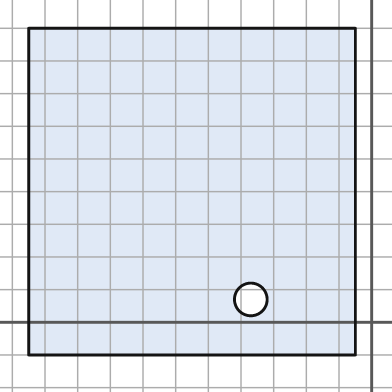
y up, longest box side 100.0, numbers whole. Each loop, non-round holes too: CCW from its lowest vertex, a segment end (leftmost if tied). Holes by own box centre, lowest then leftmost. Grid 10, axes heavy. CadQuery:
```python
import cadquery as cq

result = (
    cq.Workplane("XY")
    .moveTo(-105.0, -10.0)
    .lineTo(-5.0, -10.0)
    .lineTo(-5.0, 90.0)
    .lineTo(-105.0, 90.0)
    .close()
    .moveTo(-37.0, 7.0)
    .circle(5.0)
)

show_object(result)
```